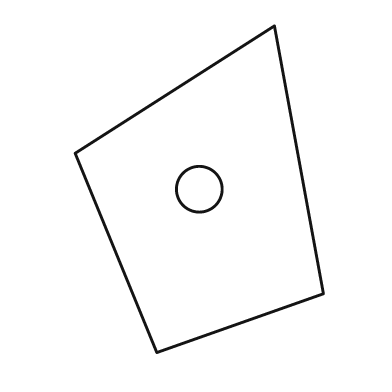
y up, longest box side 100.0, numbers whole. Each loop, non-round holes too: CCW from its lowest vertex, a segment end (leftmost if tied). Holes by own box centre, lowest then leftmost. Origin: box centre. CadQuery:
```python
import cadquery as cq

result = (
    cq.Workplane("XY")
    .moveTo(-13.0, -50.0)
    .lineTo(38.0, -32.0)
    .lineTo(23.0, 50.0)
    .lineTo(-38.0, 11.0)
    .close()
    .moveTo(0.0, 0.0)
    .circle(7.0)
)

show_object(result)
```